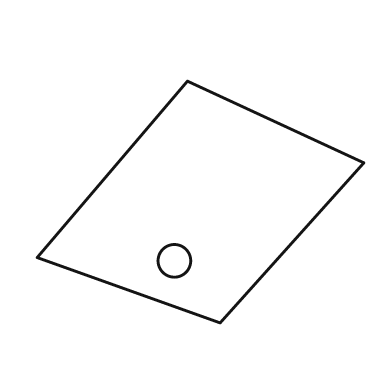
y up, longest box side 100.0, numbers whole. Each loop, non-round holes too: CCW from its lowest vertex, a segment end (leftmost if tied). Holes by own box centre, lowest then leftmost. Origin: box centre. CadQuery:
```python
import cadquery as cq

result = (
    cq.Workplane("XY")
    .moveTo(6.0, -37.0)
    .lineTo(50.0, 12.0)
    .lineTo(-4.0, 37.0)
    .lineTo(-50.0, -17.0)
    .close()
    .moveTo(-8.0, -18.0)
    .circle(5.0)
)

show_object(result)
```